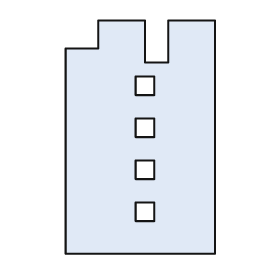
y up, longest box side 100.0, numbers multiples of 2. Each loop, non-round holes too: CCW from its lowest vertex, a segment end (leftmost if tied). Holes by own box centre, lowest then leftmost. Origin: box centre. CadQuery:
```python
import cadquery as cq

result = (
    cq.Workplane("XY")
    .moveTo(-32.0, -50.0)
    .lineTo(32.0, -50.0)
    .lineTo(32.0, 50.0)
    .lineTo(12.0, 50.0)
    .lineTo(12.0, 32.0)
    .lineTo(2.0, 32.0)
    .lineTo(2.0, 50.0)
    .lineTo(-18.0, 50.0)
    .lineTo(-18.0, 38.0)
    .lineTo(-32.0, 38.0)
    .close()
    .moveTo(-2.0, -36.0)
    .lineTo(6.0, -36.0)
    .lineTo(6.0, -28.0)
    .lineTo(-2.0, -28.0)
    .close()
    .moveTo(-2.0, -18.0)
    .lineTo(6.0, -18.0)
    .lineTo(6.0, -10.0)
    .lineTo(-2.0, -10.0)
    .close()
    .moveTo(-2.0, 0.0)
    .lineTo(6.0, 0.0)
    .lineTo(6.0, 8.0)
    .lineTo(-2.0, 8.0)
    .close()
    .moveTo(-2.0, 18.0)
    .lineTo(6.0, 18.0)
    .lineTo(6.0, 26.0)
    .lineTo(-2.0, 26.0)
    .close()
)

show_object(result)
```